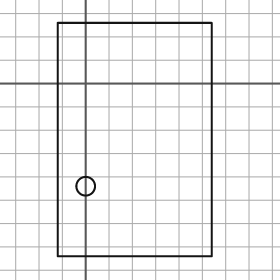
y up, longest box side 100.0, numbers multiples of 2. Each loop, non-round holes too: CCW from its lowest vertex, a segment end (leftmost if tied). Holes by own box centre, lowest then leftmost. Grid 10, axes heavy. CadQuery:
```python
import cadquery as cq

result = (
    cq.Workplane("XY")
    .moveTo(-12.0, -74.0)
    .lineTo(54.0, -74.0)
    .lineTo(54.0, 26.0)
    .lineTo(-12.0, 26.0)
    .close()
    .moveTo(0.0, -44.0)
    .circle(4.0)
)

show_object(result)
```